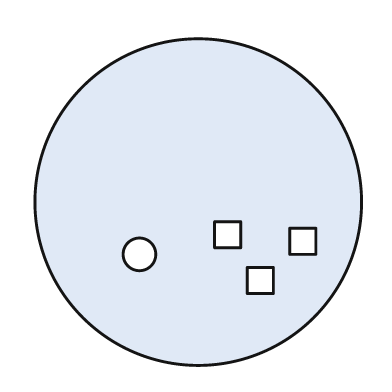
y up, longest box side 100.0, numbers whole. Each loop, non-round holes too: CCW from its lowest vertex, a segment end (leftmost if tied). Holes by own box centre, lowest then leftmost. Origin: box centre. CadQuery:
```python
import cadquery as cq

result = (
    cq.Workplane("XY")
    .moveTo(0.0, 0.0)
    .circle(50.0)
    .moveTo(15.0, -28.0)
    .lineTo(23.0, -28.0)
    .lineTo(23.0, -20.0)
    .lineTo(15.0, -20.0)
    .close()
    .moveTo(-18.0, -16.0)
    .circle(5.0)
    .moveTo(28.0, -16.0)
    .lineTo(36.0, -16.0)
    .lineTo(36.0, -8.0)
    .lineTo(28.0, -8.0)
    .close()
    .moveTo(5.0, -14.0)
    .lineTo(13.0, -14.0)
    .lineTo(13.0, -6.0)
    .lineTo(5.0, -6.0)
    .close()
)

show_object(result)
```